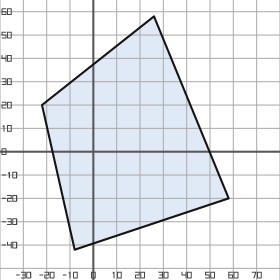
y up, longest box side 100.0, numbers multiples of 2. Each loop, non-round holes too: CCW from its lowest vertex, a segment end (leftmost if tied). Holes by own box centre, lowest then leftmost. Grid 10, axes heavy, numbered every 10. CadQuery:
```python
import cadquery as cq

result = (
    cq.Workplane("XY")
    .moveTo(-8.0, -42.0)
    .lineTo(58.0, -20.0)
    .lineTo(26.0, 58.0)
    .lineTo(-22.0, 20.0)
    .close()
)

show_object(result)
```